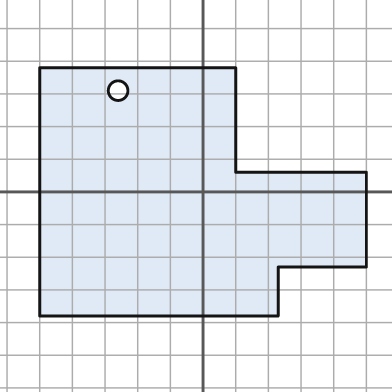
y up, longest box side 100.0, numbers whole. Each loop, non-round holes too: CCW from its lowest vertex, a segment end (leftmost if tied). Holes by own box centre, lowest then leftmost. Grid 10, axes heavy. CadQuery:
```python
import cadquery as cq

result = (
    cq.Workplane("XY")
    .moveTo(-50.0, -38.0)
    .lineTo(23.0, -38.0)
    .lineTo(23.0, -23.0)
    .lineTo(50.0, -23.0)
    .lineTo(50.0, 6.0)
    .lineTo(10.0, 6.0)
    .lineTo(10.0, 38.0)
    .lineTo(-50.0, 38.0)
    .close()
    .moveTo(-26.0, 31.0)
    .circle(3.0)
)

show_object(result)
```